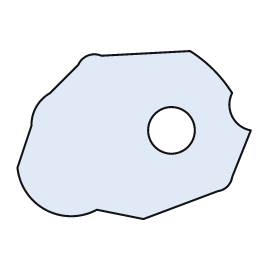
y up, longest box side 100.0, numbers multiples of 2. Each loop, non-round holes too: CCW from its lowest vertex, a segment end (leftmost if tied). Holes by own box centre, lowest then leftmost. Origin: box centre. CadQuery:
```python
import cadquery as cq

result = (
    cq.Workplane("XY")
    .moveTo(4.0, -36.0)
    .lineTo(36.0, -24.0)
    .threePointArc((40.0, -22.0), (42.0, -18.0))
    .lineTo(50.0, 2.0)
    .threePointArc((42.0, 8.0), (42.0, 18.0))
    .threePointArc((34.0, 28.0), (24.0, 36.0))
    .lineTo(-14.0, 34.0)
    .threePointArc((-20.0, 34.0), (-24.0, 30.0))
    .lineTo(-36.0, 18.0)
    .threePointArc((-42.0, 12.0), (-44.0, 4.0))
    .lineTo(-50.0, -14.0)
    .threePointArc((-38.0, -32.0), (-16.0, -32.0))
    .close()
    .moveTo(16.0, 2.0)
    .circle(10.0)
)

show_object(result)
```